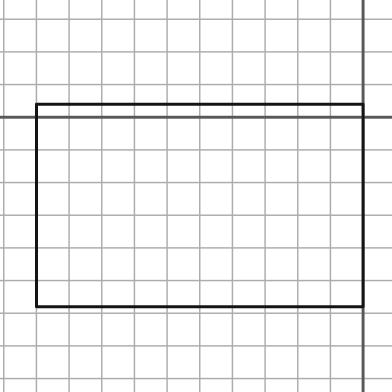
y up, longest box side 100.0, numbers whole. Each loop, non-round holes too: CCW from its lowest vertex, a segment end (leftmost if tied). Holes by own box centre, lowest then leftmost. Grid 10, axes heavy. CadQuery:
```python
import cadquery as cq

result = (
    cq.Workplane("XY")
    .moveTo(-100.0, -58.0)
    .lineTo(0.0, -58.0)
    .lineTo(0.0, 4.0)
    .lineTo(-100.0, 4.0)
    .close()
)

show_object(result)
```